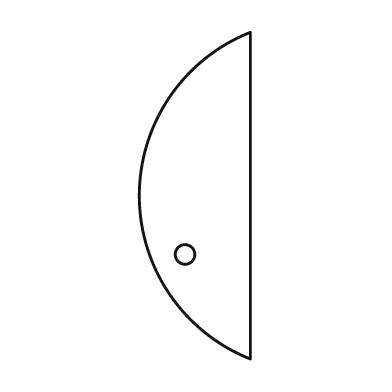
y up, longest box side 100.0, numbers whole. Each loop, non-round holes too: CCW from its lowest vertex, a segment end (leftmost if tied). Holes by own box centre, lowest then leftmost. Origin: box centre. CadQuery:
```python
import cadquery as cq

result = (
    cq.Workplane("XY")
    .moveTo(17.0, -50.0)
    .lineTo(17.0, 50.0)
    .threePointArc((-17.0, 0.0), (17.0, -50.0))
    .close()
    .moveTo(-3.0, -18.0)
    .circle(3.0)
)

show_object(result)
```